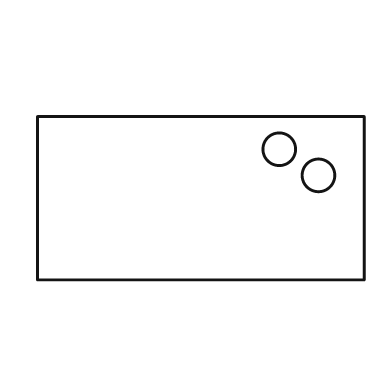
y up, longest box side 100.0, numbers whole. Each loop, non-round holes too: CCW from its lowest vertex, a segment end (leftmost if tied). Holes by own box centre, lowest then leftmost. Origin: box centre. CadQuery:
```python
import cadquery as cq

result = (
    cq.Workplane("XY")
    .moveTo(-50.0, -25.0)
    .lineTo(50.0, -25.0)
    .lineTo(50.0, 25.0)
    .lineTo(-50.0, 25.0)
    .close()
    .moveTo(36.0, 7.0)
    .circle(5.0)
    .moveTo(24.0, 15.0)
    .circle(5.0)
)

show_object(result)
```